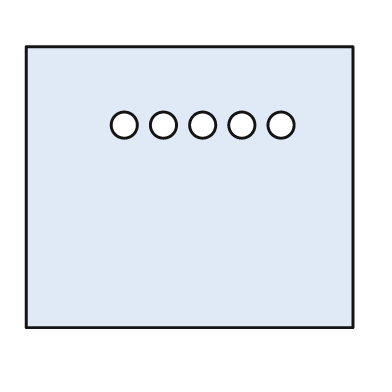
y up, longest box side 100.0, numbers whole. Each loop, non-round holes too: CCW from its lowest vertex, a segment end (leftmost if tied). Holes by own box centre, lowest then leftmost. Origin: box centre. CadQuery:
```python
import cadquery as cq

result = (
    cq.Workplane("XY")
    .moveTo(-50.0, -43.0)
    .lineTo(50.0, -43.0)
    .lineTo(50.0, 43.0)
    .lineTo(-50.0, 43.0)
    .close()
    .moveTo(-20.0, 19.0)
    .circle(4.0)
    .moveTo(-8.0, 19.0)
    .circle(4.0)
    .moveTo(4.0, 19.0)
    .circle(4.0)
    .moveTo(16.0, 19.0)
    .circle(4.0)
    .moveTo(28.0, 19.0)
    .circle(4.0)
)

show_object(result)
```